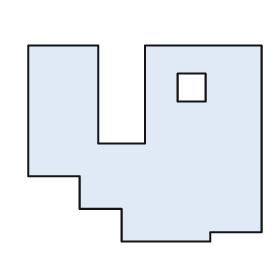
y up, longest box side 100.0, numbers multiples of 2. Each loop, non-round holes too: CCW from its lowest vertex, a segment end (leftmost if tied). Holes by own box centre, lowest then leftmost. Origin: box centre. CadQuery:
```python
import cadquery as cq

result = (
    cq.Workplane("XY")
    .moveTo(-10.0, -42.0)
    .lineTo(28.0, -42.0)
    .lineTo(28.0, -38.0)
    .lineTo(50.0, -38.0)
    .lineTo(50.0, 42.0)
    .lineTo(0.0, 42.0)
    .lineTo(0.0, 0.0)
    .lineTo(-20.0, 0.0)
    .lineTo(-20.0, 42.0)
    .lineTo(-50.0, 42.0)
    .lineTo(-50.0, -14.0)
    .lineTo(-28.0, -14.0)
    .lineTo(-28.0, -28.0)
    .lineTo(-10.0, -28.0)
    .close()
    .moveTo(14.0, 18.0)
    .lineTo(26.0, 18.0)
    .lineTo(26.0, 30.0)
    .lineTo(14.0, 30.0)
    .close()
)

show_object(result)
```